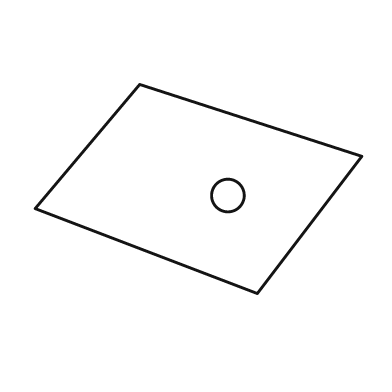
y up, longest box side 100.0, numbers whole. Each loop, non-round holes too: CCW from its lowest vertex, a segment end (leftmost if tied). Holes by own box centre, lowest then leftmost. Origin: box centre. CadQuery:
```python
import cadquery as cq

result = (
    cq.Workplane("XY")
    .moveTo(18.0, -32.0)
    .lineTo(50.0, 10.0)
    .lineTo(-18.0, 32.0)
    .lineTo(-50.0, -6.0)
    .close()
    .moveTo(9.0, -2.0)
    .circle(5.0)
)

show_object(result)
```